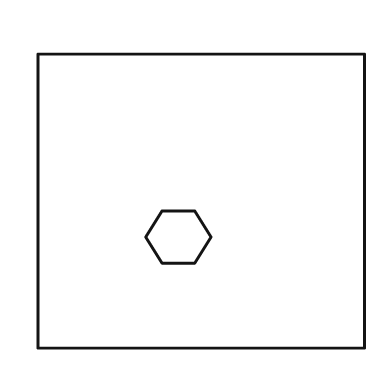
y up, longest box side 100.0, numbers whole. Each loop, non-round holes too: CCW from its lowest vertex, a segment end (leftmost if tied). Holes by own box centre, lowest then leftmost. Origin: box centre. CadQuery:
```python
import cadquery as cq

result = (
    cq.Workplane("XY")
    .moveTo(-50.0, -45.0)
    .lineTo(50.0, -45.0)
    .lineTo(50.0, 45.0)
    .lineTo(-50.0, 45.0)
    .close()
    .moveTo(-12.0, -19.0)
    .lineTo(-2.0, -19.0)
    .lineTo(3.0, -11.0)
    .lineTo(-2.0, -3.0)
    .lineTo(-12.0, -3.0)
    .lineTo(-17.0, -11.0)
    .close()
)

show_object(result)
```